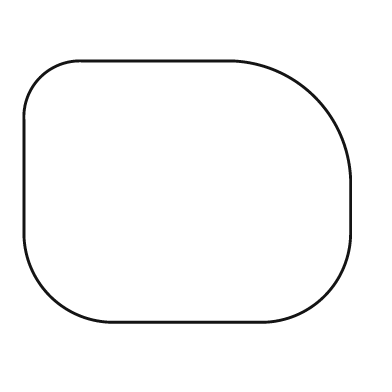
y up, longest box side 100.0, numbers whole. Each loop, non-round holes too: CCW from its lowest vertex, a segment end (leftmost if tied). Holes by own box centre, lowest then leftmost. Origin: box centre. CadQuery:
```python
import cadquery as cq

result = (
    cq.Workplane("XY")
    .moveTo(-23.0, -40.0)
    .lineTo(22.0, -40.0)
    .threePointArc((42.0, -32.0), (50.0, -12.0))
    .lineTo(50.0, 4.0)
    .threePointArc((39.0, 29.0), (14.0, 40.0))
    .lineTo(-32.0, 40.0)
    .threePointArc((-45.0, 35.0), (-50.0, 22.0))
    .lineTo(-50.0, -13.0)
    .threePointArc((-42.0, -32.0), (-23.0, -40.0))
    .close()
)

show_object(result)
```